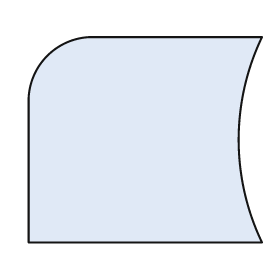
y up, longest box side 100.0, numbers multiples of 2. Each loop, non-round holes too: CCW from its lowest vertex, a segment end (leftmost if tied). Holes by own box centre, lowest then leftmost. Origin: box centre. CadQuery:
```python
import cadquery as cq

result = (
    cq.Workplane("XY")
    .moveTo(-50.0, -44.0)
    .lineTo(50.0, -44.0)
    .threePointArc((40.0, 0.0), (50.0, 44.0))
    .lineTo(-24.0, 44.0)
    .threePointArc((-42.0, 36.0), (-50.0, 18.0))
    .close()
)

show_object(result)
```